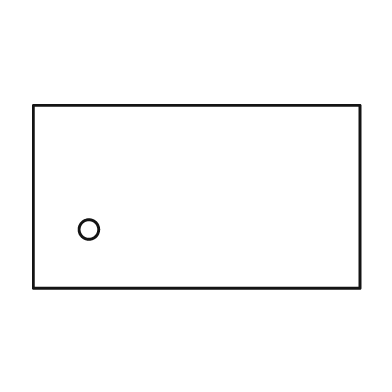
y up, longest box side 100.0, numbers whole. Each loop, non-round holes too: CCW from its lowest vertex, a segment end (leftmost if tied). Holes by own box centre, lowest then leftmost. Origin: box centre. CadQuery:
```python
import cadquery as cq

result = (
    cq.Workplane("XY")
    .moveTo(-50.0, -28.0)
    .lineTo(50.0, -28.0)
    .lineTo(50.0, 28.0)
    .lineTo(-50.0, 28.0)
    .close()
    .moveTo(-33.0, -10.0)
    .circle(3.0)
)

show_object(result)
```